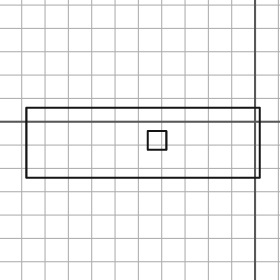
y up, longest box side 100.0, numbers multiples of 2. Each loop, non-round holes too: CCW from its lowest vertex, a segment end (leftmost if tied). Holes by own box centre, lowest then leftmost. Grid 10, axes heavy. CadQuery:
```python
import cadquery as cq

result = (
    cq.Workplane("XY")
    .moveTo(-98.0, -24.0)
    .lineTo(2.0, -24.0)
    .lineTo(2.0, 6.0)
    .lineTo(-98.0, 6.0)
    .close()
    .moveTo(-46.0, -12.0)
    .lineTo(-38.0, -12.0)
    .lineTo(-38.0, -4.0)
    .lineTo(-46.0, -4.0)
    .close()
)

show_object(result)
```